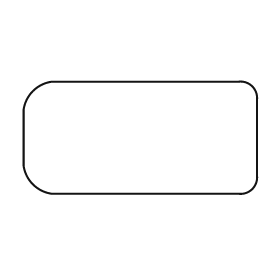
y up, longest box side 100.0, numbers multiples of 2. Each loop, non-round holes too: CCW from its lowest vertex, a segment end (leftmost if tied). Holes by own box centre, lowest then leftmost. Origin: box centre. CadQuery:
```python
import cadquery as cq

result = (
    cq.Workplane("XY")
    .moveTo(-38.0, -24.0)
    .lineTo(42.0, -24.0)
    .threePointArc((48.0, -22.0), (50.0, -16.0))
    .lineTo(50.0, 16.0)
    .threePointArc((48.0, 22.0), (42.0, 24.0))
    .lineTo(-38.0, 24.0)
    .threePointArc((-46.0, 20.0), (-50.0, 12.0))
    .lineTo(-50.0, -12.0)
    .threePointArc((-46.0, -20.0), (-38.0, -24.0))
    .close()
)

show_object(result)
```